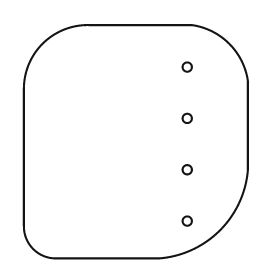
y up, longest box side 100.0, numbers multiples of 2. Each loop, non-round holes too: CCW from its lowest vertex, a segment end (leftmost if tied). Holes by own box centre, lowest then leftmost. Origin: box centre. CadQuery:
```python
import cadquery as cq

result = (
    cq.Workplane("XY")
    .moveTo(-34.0, -50.0)
    .lineTo(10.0, -50.0)
    .threePointArc((36.0, -38.0), (48.0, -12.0))
    .lineTo(48.0, 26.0)
    .threePointArc((40.0, 42.0), (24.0, 50.0))
    .lineTo(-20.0, 50.0)
    .threePointArc((-40.0, 42.0), (-48.0, 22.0))
    .lineTo(-48.0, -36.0)
    .threePointArc((-44.0, -46.0), (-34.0, -50.0))
    .close()
    .moveTo(22.0, -34.0)
    .circle(2.0)
    .moveTo(22.0, -12.0)
    .circle(2.0)
    .moveTo(22.0, 10.0)
    .circle(2.0)
    .moveTo(22.0, 32.0)
    .circle(2.0)
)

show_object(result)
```